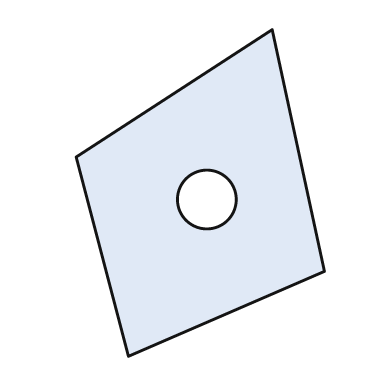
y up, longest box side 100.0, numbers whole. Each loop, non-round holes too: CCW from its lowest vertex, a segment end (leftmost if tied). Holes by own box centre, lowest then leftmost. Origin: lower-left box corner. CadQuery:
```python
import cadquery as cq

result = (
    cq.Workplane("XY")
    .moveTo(16.0, 0.0)
    .lineTo(76.0, 26.0)
    .lineTo(60.0, 100.0)
    .lineTo(0.0, 61.0)
    .close()
    .moveTo(40.0, 48.0)
    .circle(9.0)
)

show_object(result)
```